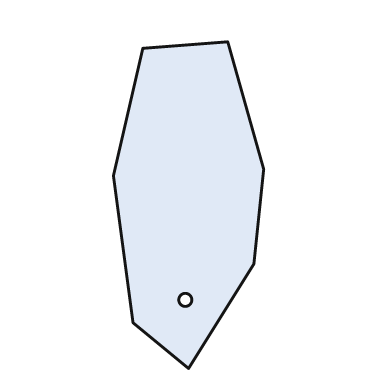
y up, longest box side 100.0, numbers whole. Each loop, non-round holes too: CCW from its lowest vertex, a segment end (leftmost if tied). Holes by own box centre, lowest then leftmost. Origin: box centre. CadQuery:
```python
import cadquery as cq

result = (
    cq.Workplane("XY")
    .moveTo(0.0, -50.0)
    .lineTo(20.0, -18.0)
    .lineTo(23.0, 11.0)
    .lineTo(12.0, 50.0)
    .lineTo(-14.0, 48.0)
    .lineTo(-23.0, 9.0)
    .lineTo(-17.0, -36.0)
    .close()
    .moveTo(-1.0, -29.0)
    .circle(2.0)
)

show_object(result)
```